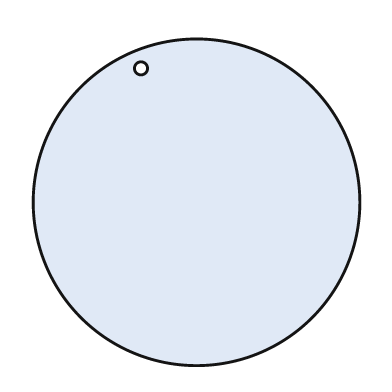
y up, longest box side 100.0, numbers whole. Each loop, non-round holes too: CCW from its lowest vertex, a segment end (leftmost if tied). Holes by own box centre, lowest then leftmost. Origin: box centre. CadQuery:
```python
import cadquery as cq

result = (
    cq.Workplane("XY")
    .moveTo(0.0, 0.0)
    .circle(50.0)
    .moveTo(-17.0, 41.0)
    .circle(2.0)
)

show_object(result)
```